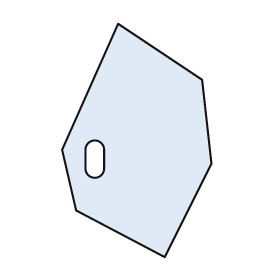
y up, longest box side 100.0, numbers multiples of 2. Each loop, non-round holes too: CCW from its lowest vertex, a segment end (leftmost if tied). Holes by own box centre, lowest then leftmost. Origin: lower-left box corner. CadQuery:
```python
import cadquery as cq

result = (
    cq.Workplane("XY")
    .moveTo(44.0, 0.0)
    .lineTo(64.0, 40.0)
    .lineTo(60.0, 76.0)
    .lineTo(24.0, 100.0)
    .lineTo(0.0, 46.0)
    .lineTo(6.0, 20.0)
    .close()
    .moveTo(10.0, 38.0)
    .threePointArc((14.0, 34.0), (18.0, 38.0))
    .lineTo(18.0, 46.0)
    .threePointArc((14.0, 50.0), (10.0, 46.0))
    .close()
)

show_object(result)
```